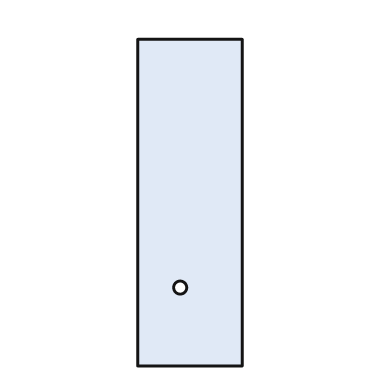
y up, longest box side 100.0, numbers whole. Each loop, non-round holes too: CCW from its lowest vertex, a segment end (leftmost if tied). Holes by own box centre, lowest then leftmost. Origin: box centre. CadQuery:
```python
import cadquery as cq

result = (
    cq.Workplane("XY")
    .moveTo(-16.0, -50.0)
    .lineTo(16.0, -50.0)
    .lineTo(16.0, 50.0)
    .lineTo(-16.0, 50.0)
    .close()
    .moveTo(-3.0, -26.0)
    .circle(2.0)
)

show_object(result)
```